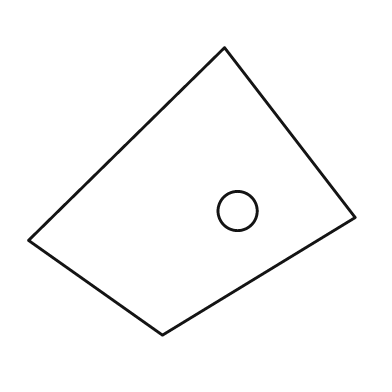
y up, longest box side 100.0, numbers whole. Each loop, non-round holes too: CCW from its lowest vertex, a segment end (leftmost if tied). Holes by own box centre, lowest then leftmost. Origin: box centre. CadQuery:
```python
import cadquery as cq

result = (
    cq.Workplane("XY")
    .moveTo(-9.0, -44.0)
    .lineTo(50.0, -8.0)
    .lineTo(10.0, 44.0)
    .lineTo(-50.0, -15.0)
    .close()
    .moveTo(14.0, -6.0)
    .circle(6.0)
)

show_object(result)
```